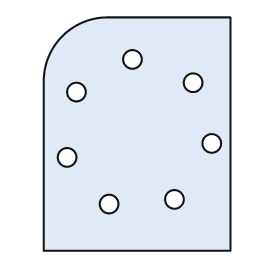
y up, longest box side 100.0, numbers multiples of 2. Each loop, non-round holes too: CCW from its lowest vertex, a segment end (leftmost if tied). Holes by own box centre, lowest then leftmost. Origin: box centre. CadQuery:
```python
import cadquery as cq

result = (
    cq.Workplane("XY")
    .moveTo(-40.0, -50.0)
    .lineTo(40.0, -50.0)
    .lineTo(40.0, 50.0)
    .lineTo(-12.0, 50.0)
    .threePointArc((-32.0, 42.0), (-40.0, 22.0))
    .close()
    .moveTo(-12.0, -30.0)
    .circle(4.0)
    .moveTo(16.0, -28.0)
    .circle(4.0)
    .moveTo(-30.0, -10.0)
    .circle(4.0)
    .moveTo(32.0, -4.0)
    .circle(4.0)
    .moveTo(-26.0, 18.0)
    .circle(4.0)
    .moveTo(24.0, 22.0)
    .circle(4.0)
    .moveTo(-2.0, 32.0)
    .circle(4.0)
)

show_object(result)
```